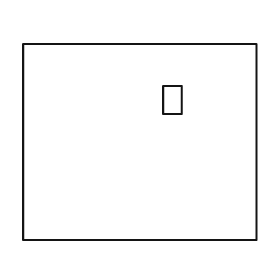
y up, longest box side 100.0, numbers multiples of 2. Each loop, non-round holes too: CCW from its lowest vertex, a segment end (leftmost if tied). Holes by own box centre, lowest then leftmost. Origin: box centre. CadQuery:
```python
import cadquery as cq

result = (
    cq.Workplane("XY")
    .moveTo(-50.0, -42.0)
    .lineTo(50.0, -42.0)
    .lineTo(50.0, 42.0)
    .lineTo(-50.0, 42.0)
    .close()
    .moveTo(10.0, 12.0)
    .lineTo(18.0, 12.0)
    .lineTo(18.0, 24.0)
    .lineTo(10.0, 24.0)
    .close()
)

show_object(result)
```